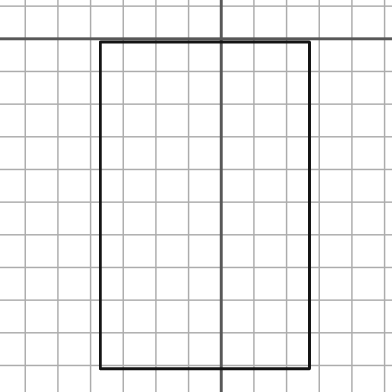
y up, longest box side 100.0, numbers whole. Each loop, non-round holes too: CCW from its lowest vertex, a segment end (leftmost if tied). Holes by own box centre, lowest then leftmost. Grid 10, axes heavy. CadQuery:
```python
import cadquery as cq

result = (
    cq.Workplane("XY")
    .moveTo(-37.0, -101.0)
    .lineTo(27.0, -101.0)
    .lineTo(27.0, -1.0)
    .lineTo(-37.0, -1.0)
    .close()
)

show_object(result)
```